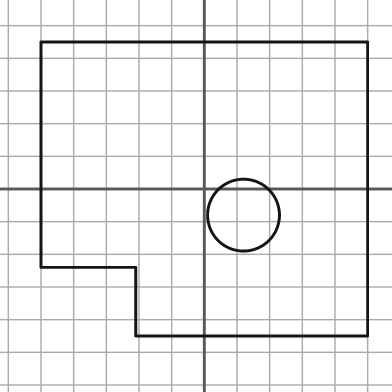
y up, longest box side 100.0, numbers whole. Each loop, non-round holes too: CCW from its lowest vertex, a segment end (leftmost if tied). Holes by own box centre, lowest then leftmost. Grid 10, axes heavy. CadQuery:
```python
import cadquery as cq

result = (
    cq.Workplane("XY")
    .moveTo(-21.0, -45.0)
    .lineTo(50.0, -45.0)
    .lineTo(50.0, 45.0)
    .lineTo(-50.0, 45.0)
    .lineTo(-50.0, -24.0)
    .lineTo(-21.0, -24.0)
    .close()
    .moveTo(12.0, -8.0)
    .circle(11.0)
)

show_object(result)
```